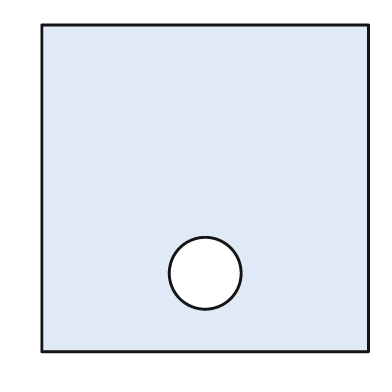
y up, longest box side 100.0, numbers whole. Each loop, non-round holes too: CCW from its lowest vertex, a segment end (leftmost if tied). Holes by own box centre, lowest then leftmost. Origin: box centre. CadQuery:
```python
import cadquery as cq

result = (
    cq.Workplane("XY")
    .moveTo(-50.0, -50.0)
    .lineTo(50.0, -50.0)
    .lineTo(50.0, 50.0)
    .lineTo(-50.0, 50.0)
    .close()
    .moveTo(0.0, -26.0)
    .circle(11.0)
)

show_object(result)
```